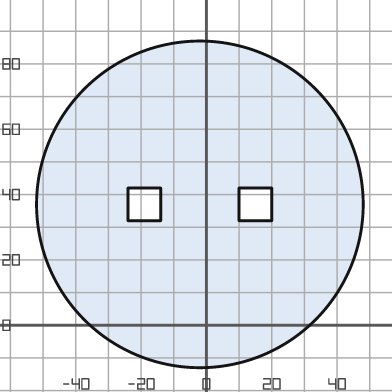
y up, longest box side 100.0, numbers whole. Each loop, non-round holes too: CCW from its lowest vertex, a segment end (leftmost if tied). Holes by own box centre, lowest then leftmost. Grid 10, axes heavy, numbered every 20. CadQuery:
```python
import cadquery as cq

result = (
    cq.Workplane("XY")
    .moveTo(-2.0, 37.0)
    .circle(50.0)
    .moveTo(-24.0, 32.0)
    .lineTo(-14.0, 32.0)
    .lineTo(-14.0, 42.0)
    .lineTo(-24.0, 42.0)
    .close()
    .moveTo(10.0, 32.0)
    .lineTo(20.0, 32.0)
    .lineTo(20.0, 42.0)
    .lineTo(10.0, 42.0)
    .close()
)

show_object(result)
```